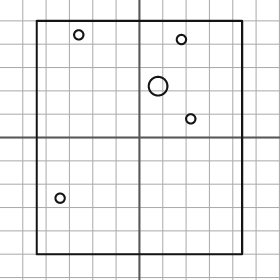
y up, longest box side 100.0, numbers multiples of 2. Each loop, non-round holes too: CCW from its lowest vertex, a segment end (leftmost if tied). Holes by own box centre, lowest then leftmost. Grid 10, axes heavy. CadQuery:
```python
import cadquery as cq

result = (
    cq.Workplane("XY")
    .moveTo(-44.0, -50.0)
    .lineTo(44.0, -50.0)
    .lineTo(44.0, 50.0)
    .lineTo(-44.0, 50.0)
    .close()
    .moveTo(-34.0, -26.0)
    .circle(2.0)
    .moveTo(22.0, 8.0)
    .circle(2.0)
    .moveTo(8.0, 22.0)
    .circle(4.0)
    .moveTo(18.0, 42.0)
    .circle(2.0)
    .moveTo(-26.0, 44.0)
    .circle(2.0)
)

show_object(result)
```